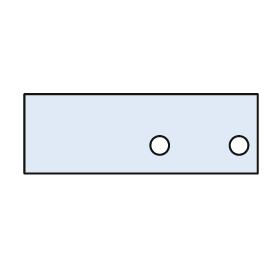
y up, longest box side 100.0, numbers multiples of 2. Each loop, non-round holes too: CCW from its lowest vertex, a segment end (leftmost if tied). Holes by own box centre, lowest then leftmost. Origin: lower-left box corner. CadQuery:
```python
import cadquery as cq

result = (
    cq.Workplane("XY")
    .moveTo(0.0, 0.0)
    .lineTo(100.0, 0.0)
    .lineTo(100.0, 34.0)
    .lineTo(0.0, 34.0)
    .close()
    .moveTo(58.0, 12.0)
    .circle(4.0)
    .moveTo(92.0, 12.0)
    .circle(4.0)
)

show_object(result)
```